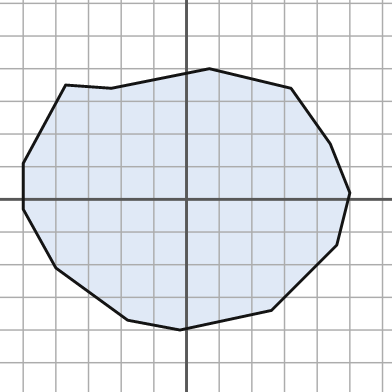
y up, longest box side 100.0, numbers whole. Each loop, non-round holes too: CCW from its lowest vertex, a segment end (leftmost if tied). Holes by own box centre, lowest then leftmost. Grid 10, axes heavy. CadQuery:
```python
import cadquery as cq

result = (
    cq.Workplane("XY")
    .moveTo(-2.0, -40.0)
    .lineTo(26.0, -34.0)
    .lineTo(46.0, -14.0)
    .lineTo(50.0, 2.0)
    .lineTo(44.0, 17.0)
    .lineTo(32.0, 34.0)
    .lineTo(7.0, 40.0)
    .lineTo(-23.0, 34.0)
    .lineTo(-37.0, 35.0)
    .lineTo(-50.0, 11.0)
    .lineTo(-50.0, -3.0)
    .lineTo(-40.0, -21.0)
    .lineTo(-18.0, -37.0)
    .close()
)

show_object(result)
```